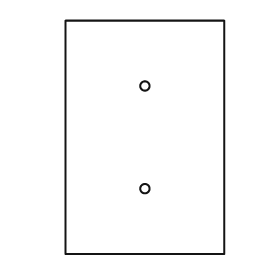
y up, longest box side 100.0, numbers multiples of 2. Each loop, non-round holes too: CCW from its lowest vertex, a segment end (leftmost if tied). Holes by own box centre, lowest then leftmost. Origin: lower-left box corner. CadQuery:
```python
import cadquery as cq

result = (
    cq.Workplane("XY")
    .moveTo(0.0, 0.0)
    .lineTo(68.0, 0.0)
    .lineTo(68.0, 100.0)
    .lineTo(0.0, 100.0)
    .close()
    .moveTo(34.0, 28.0)
    .circle(2.0)
    .moveTo(34.0, 72.0)
    .circle(2.0)
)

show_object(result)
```